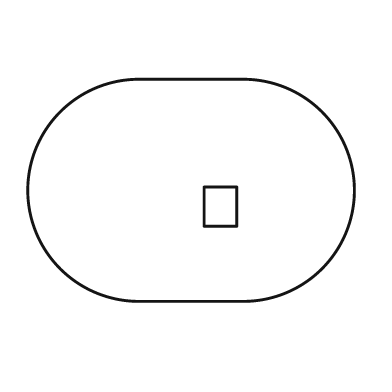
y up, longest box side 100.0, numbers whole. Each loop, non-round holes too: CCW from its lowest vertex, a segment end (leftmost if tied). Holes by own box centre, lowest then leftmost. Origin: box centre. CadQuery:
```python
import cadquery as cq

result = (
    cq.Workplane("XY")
    .moveTo(-16.0, -34.0)
    .lineTo(16.0, -34.0)
    .threePointArc((50.0, 0.0), (16.0, 34.0))
    .lineTo(-16.0, 34.0)
    .threePointArc((-50.0, 0.0), (-16.0, -34.0))
    .close()
    .moveTo(4.0, -11.0)
    .lineTo(14.0, -11.0)
    .lineTo(14.0, 1.0)
    .lineTo(4.0, 1.0)
    .close()
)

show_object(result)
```